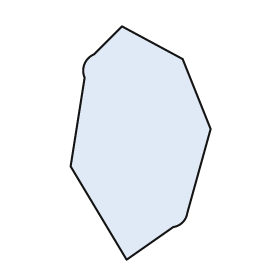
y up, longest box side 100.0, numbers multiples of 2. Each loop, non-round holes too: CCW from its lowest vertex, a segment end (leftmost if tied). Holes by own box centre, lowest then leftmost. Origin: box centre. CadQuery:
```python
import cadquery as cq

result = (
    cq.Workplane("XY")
    .moveTo(-6.0, -50.0)
    .lineTo(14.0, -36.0)
    .threePointArc((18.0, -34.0), (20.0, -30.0))
    .lineTo(30.0, 6.0)
    .lineTo(18.0, 36.0)
    .lineTo(-8.0, 50.0)
    .lineTo(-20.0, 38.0)
    .threePointArc((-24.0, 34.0), (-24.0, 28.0))
    .lineTo(-30.0, -10.0)
    .close()
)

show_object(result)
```